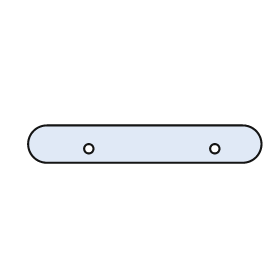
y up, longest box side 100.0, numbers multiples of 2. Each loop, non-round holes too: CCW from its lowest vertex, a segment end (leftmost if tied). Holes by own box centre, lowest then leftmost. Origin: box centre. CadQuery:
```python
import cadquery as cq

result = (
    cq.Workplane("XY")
    .moveTo(-42.0, -8.0)
    .lineTo(42.0, -8.0)
    .threePointArc((50.0, 0.0), (42.0, 8.0))
    .lineTo(-42.0, 8.0)
    .threePointArc((-50.0, 0.0), (-42.0, -8.0))
    .close()
    .moveTo(-24.0, -2.0)
    .circle(2.0)
    .moveTo(30.0, -2.0)
    .circle(2.0)
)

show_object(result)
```